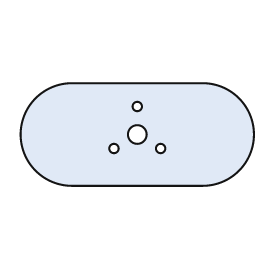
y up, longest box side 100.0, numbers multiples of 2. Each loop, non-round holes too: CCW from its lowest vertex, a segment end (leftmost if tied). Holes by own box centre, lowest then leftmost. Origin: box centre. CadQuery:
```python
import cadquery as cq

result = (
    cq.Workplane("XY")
    .moveTo(-28.0, -22.0)
    .lineTo(28.0, -22.0)
    .threePointArc((50.0, 0.0), (28.0, 22.0))
    .lineTo(-28.0, 22.0)
    .threePointArc((-50.0, 0.0), (-28.0, -22.0))
    .close()
    .moveTo(-10.0, -6.0)
    .circle(2.0)
    .moveTo(10.0, -6.0)
    .circle(2.0)
    .moveTo(0.0, 0.0)
    .circle(4.0)
    .moveTo(0.0, 12.0)
    .circle(2.0)
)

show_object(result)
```